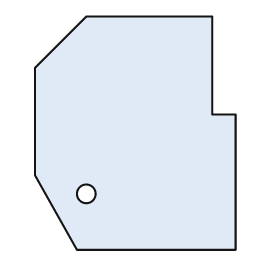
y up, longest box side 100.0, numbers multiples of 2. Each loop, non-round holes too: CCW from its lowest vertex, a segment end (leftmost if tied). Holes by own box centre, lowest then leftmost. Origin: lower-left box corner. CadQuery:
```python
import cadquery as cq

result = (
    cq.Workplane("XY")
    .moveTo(18.0, 0.0)
    .lineTo(86.0, 0.0)
    .lineTo(86.0, 58.0)
    .lineTo(76.0, 58.0)
    .lineTo(76.0, 100.0)
    .lineTo(22.0, 100.0)
    .lineTo(0.0, 78.0)
    .lineTo(0.0, 32.0)
    .close()
    .moveTo(22.0, 24.0)
    .circle(4.0)
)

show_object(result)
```